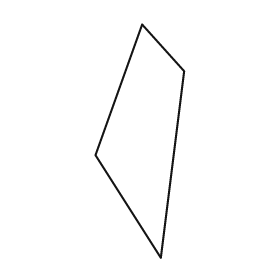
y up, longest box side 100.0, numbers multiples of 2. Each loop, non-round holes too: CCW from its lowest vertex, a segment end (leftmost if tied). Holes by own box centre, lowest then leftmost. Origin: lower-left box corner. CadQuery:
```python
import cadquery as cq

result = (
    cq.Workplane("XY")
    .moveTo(28.0, 0.0)
    .lineTo(38.0, 80.0)
    .lineTo(20.0, 100.0)
    .lineTo(0.0, 44.0)
    .close()
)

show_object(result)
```